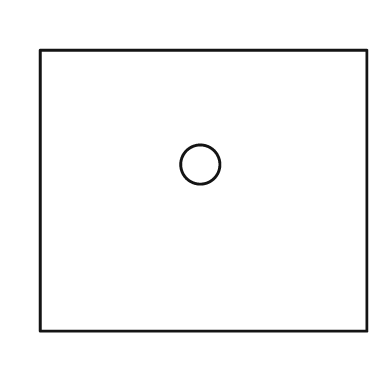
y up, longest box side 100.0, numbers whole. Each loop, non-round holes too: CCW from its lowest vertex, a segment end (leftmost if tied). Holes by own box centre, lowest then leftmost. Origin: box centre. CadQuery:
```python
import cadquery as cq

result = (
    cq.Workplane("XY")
    .moveTo(-50.0, -43.0)
    .lineTo(50.0, -43.0)
    .lineTo(50.0, 43.0)
    .lineTo(-50.0, 43.0)
    .close()
    .moveTo(-1.0, 8.0)
    .circle(6.0)
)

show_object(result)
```